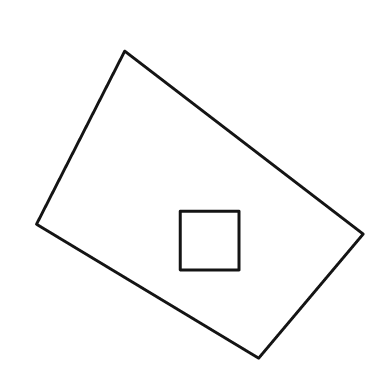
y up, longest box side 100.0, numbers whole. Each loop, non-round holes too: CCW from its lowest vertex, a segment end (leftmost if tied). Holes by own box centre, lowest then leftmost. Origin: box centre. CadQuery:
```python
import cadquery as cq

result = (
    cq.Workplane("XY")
    .moveTo(18.0, -47.0)
    .lineTo(50.0, -9.0)
    .lineTo(-23.0, 47.0)
    .lineTo(-50.0, -6.0)
    .close()
    .moveTo(-6.0, -20.0)
    .lineTo(12.0, -20.0)
    .lineTo(12.0, -2.0)
    .lineTo(-6.0, -2.0)
    .close()
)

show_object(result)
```